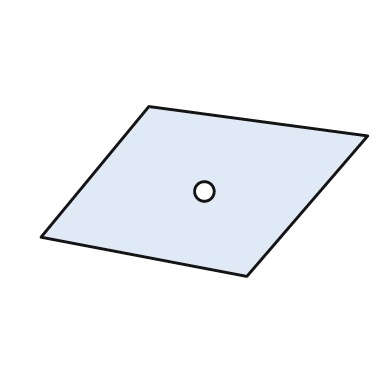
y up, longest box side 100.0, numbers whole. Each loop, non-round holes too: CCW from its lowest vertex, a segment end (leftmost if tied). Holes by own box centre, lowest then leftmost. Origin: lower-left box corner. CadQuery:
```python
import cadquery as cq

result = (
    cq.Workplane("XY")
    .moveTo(63.0, 0.0)
    .lineTo(100.0, 43.0)
    .lineTo(33.0, 52.0)
    .lineTo(0.0, 12.0)
    .close()
    .moveTo(50.0, 26.0)
    .circle(3.0)
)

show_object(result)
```